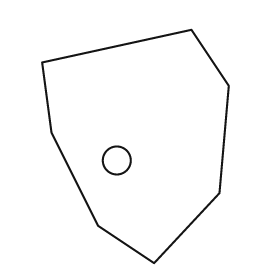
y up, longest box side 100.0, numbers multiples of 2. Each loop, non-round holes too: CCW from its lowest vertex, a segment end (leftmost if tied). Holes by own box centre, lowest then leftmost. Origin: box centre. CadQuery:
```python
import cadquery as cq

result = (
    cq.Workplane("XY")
    .moveTo(8.0, -50.0)
    .lineTo(36.0, -20.0)
    .lineTo(40.0, 26.0)
    .lineTo(24.0, 50.0)
    .lineTo(-40.0, 36.0)
    .lineTo(-36.0, 6.0)
    .lineTo(-16.0, -34.0)
    .close()
    .moveTo(-8.0, -6.0)
    .circle(6.0)
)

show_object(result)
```